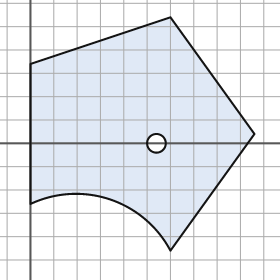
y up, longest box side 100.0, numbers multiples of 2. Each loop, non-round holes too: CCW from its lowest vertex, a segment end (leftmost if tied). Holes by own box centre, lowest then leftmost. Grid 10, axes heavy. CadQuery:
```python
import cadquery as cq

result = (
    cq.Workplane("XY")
    .moveTo(60.0, -46.0)
    .lineTo(96.0, 4.0)
    .lineTo(60.0, 54.0)
    .lineTo(0.0, 34.0)
    .lineTo(0.0, -26.0)
    .threePointArc((34.0, -24.0), (60.0, -46.0))
    .close()
    .moveTo(54.0, 0.0)
    .circle(4.0)
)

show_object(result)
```